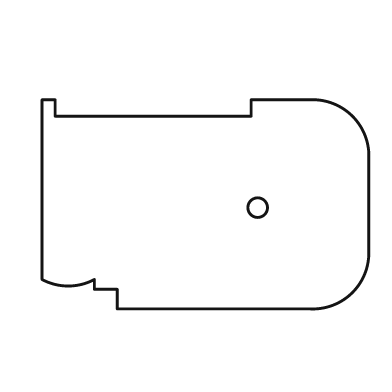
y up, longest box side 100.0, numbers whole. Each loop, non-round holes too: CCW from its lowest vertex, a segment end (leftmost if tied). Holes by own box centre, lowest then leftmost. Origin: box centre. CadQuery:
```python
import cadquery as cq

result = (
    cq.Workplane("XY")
    .moveTo(-27.0, -32.0)
    .lineTo(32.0, -32.0)
    .threePointArc((45.0, -27.0), (50.0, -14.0))
    .lineTo(50.0, 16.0)
    .threePointArc((45.0, 27.0), (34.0, 32.0))
    .lineTo(14.0, 32.0)
    .lineTo(14.0, 27.0)
    .lineTo(-46.0, 27.0)
    .lineTo(-46.0, 32.0)
    .lineTo(-50.0, 32.0)
    .lineTo(-50.0, -23.0)
    .threePointArc((-42.0, -25.0), (-34.0, -23.0))
    .lineTo(-34.0, -26.0)
    .lineTo(-27.0, -26.0)
    .close()
    .moveTo(16.0, -1.0)
    .circle(3.0)
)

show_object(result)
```